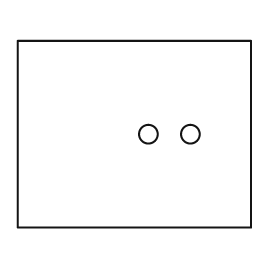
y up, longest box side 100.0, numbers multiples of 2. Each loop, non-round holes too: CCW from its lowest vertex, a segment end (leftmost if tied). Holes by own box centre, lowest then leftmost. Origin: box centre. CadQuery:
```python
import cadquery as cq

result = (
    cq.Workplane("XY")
    .moveTo(-50.0, -40.0)
    .lineTo(50.0, -40.0)
    .lineTo(50.0, 40.0)
    .lineTo(-50.0, 40.0)
    .close()
    .moveTo(6.0, 0.0)
    .circle(4.0)
    .moveTo(24.0, 0.0)
    .circle(4.0)
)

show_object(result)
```